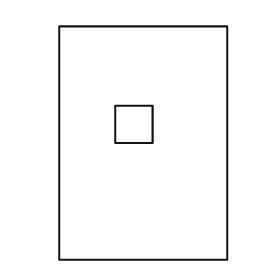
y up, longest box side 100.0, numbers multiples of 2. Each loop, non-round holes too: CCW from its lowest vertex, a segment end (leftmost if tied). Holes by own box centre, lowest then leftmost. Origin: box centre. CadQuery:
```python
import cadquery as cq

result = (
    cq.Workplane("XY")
    .moveTo(-36.0, -50.0)
    .lineTo(36.0, -50.0)
    .lineTo(36.0, 50.0)
    .lineTo(-36.0, 50.0)
    .close()
    .moveTo(-12.0, 0.0)
    .lineTo(4.0, 0.0)
    .lineTo(4.0, 16.0)
    .lineTo(-12.0, 16.0)
    .close()
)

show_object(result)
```